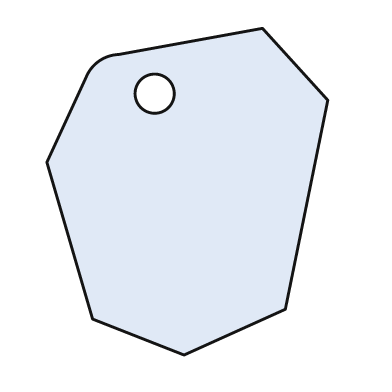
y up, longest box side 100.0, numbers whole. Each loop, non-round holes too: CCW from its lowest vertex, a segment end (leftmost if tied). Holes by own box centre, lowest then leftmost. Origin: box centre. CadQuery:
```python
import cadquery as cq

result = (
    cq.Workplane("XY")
    .moveTo(-1.0, -50.0)
    .lineTo(30.0, -36.0)
    .lineTo(43.0, 28.0)
    .lineTo(23.0, 50.0)
    .lineTo(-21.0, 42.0)
    .threePointArc((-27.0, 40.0), (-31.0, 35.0))
    .lineTo(-43.0, 9.0)
    .lineTo(-29.0, -39.0)
    .close()
    .moveTo(-10.0, 30.0)
    .circle(6.0)
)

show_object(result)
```